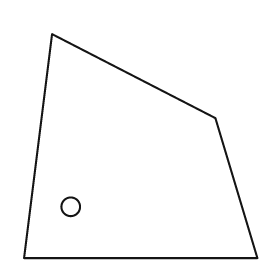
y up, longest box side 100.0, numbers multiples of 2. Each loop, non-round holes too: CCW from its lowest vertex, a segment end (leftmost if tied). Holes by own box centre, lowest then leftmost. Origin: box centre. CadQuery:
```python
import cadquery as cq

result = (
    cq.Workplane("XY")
    .moveTo(-50.0, -48.0)
    .lineTo(50.0, -48.0)
    .lineTo(32.0, 12.0)
    .lineTo(-38.0, 48.0)
    .close()
    .moveTo(-30.0, -26.0)
    .circle(4.0)
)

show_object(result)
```